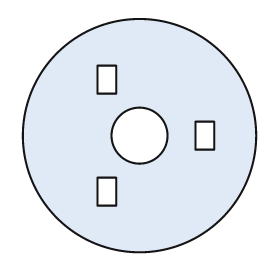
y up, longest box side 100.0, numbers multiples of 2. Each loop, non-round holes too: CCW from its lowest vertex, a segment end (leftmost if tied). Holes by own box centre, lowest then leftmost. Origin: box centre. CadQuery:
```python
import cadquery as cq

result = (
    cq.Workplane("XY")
    .moveTo(0.0, 0.0)
    .circle(50.0)
    .moveTo(-18.0, -30.0)
    .lineTo(-10.0, -30.0)
    .lineTo(-10.0, -18.0)
    .lineTo(-18.0, -18.0)
    .close()
    .moveTo(0.0, 0.0)
    .circle(12.0)
    .moveTo(24.0, -6.0)
    .lineTo(32.0, -6.0)
    .lineTo(32.0, 6.0)
    .lineTo(24.0, 6.0)
    .close()
    .moveTo(-18.0, 18.0)
    .lineTo(-10.0, 18.0)
    .lineTo(-10.0, 30.0)
    .lineTo(-18.0, 30.0)
    .close()
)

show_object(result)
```